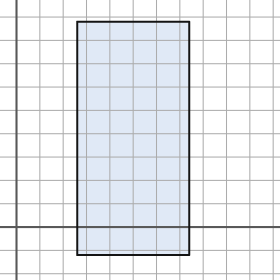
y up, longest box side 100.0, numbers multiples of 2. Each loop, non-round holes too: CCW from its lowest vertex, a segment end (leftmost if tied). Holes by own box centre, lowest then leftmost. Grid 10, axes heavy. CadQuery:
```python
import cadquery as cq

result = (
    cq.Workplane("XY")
    .moveTo(26.0, -12.0)
    .lineTo(74.0, -12.0)
    .lineTo(74.0, 88.0)
    .lineTo(26.0, 88.0)
    .close()
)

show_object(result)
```